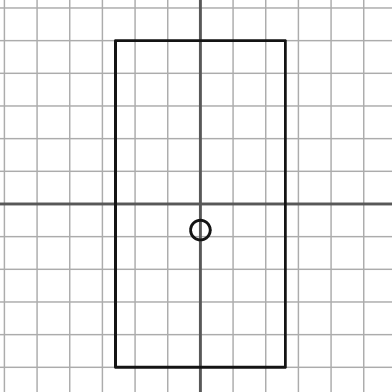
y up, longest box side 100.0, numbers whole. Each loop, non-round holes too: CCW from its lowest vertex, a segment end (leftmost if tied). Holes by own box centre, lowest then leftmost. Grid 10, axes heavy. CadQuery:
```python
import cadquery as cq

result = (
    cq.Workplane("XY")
    .moveTo(-26.0, -50.0)
    .lineTo(26.0, -50.0)
    .lineTo(26.0, 50.0)
    .lineTo(-26.0, 50.0)
    .close()
    .moveTo(0.0, -8.0)
    .circle(3.0)
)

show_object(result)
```